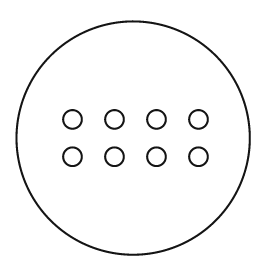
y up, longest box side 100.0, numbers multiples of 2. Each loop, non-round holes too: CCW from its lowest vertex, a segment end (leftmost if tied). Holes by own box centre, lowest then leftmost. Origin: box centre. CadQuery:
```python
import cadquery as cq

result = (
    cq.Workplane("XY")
    .moveTo(0.0, 0.0)
    .circle(50.0)
    .moveTo(-26.0, -8.0)
    .circle(4.0)
    .moveTo(-8.0, -8.0)
    .circle(4.0)
    .moveTo(10.0, -8.0)
    .circle(4.0)
    .moveTo(28.0, -8.0)
    .circle(4.0)
    .moveTo(-26.0, 8.0)
    .circle(4.0)
    .moveTo(-8.0, 8.0)
    .circle(4.0)
    .moveTo(10.0, 8.0)
    .circle(4.0)
    .moveTo(28.0, 8.0)
    .circle(4.0)
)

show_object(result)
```